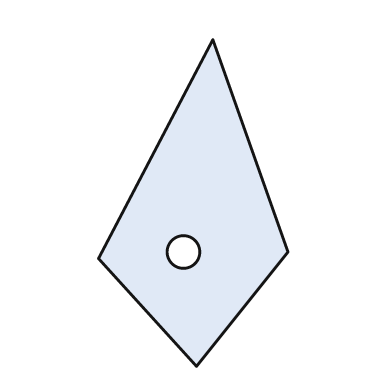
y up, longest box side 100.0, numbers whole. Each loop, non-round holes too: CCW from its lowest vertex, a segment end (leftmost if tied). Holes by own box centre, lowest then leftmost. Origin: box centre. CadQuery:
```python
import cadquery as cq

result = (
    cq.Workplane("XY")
    .moveTo(1.0, -50.0)
    .lineTo(29.0, -15.0)
    .lineTo(6.0, 50.0)
    .lineTo(-29.0, -17.0)
    .close()
    .moveTo(-3.0, -15.0)
    .circle(5.0)
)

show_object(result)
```